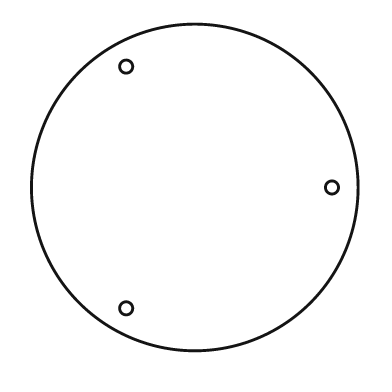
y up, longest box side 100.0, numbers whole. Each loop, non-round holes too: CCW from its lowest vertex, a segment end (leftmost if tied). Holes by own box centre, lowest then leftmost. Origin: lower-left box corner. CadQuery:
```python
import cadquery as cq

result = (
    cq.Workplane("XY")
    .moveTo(50.0, 50.0)
    .circle(50.0)
    .moveTo(29.0, 13.0)
    .circle(2.0)
    .moveTo(92.0, 50.0)
    .circle(2.0)
    .moveTo(29.0, 87.0)
    .circle(2.0)
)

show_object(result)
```